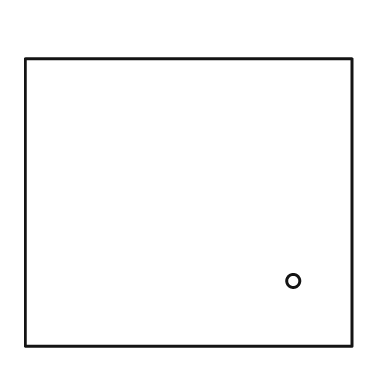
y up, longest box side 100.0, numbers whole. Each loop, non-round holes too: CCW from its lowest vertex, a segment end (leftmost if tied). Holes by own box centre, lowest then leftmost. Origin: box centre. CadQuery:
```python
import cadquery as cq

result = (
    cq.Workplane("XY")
    .moveTo(-50.0, -44.0)
    .lineTo(50.0, -44.0)
    .lineTo(50.0, 44.0)
    .lineTo(-50.0, 44.0)
    .close()
    .moveTo(32.0, -24.0)
    .circle(2.0)
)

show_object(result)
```